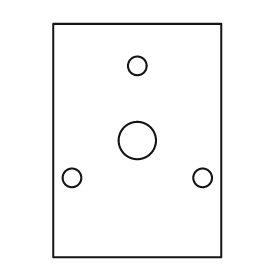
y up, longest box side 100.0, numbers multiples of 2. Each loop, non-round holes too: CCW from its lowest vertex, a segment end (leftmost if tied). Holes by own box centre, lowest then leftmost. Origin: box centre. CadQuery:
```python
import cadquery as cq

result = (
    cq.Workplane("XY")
    .moveTo(-36.0, -50.0)
    .lineTo(36.0, -50.0)
    .lineTo(36.0, 50.0)
    .lineTo(-36.0, 50.0)
    .close()
    .moveTo(-28.0, -16.0)
    .circle(4.0)
    .moveTo(28.0, -16.0)
    .circle(4.0)
    .moveTo(0.0, 0.0)
    .circle(8.0)
    .moveTo(0.0, 32.0)
    .circle(4.0)
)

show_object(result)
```